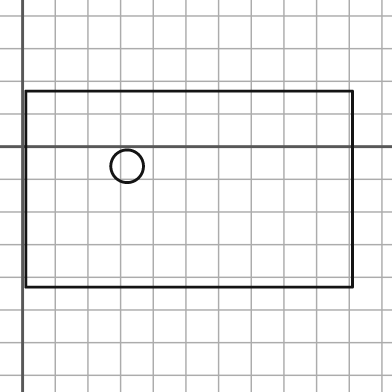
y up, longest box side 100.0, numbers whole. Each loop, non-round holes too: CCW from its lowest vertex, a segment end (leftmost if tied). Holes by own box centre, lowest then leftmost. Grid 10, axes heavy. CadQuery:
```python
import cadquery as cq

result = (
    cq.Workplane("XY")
    .moveTo(1.0, -43.0)
    .lineTo(101.0, -43.0)
    .lineTo(101.0, 17.0)
    .lineTo(1.0, 17.0)
    .close()
    .moveTo(32.0, -6.0)
    .circle(5.0)
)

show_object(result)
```